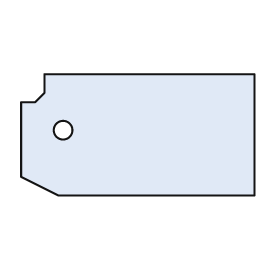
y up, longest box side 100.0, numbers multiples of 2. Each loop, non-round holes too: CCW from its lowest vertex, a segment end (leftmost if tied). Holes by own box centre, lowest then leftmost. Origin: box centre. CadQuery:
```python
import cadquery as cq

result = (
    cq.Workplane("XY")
    .moveTo(-34.0, -26.0)
    .lineTo(50.0, -26.0)
    .lineTo(50.0, 26.0)
    .lineTo(-40.0, 26.0)
    .lineTo(-40.0, 18.0)
    .lineTo(-44.0, 14.0)
    .lineTo(-50.0, 14.0)
    .lineTo(-50.0, -18.0)
    .close()
    .moveTo(-32.0, 2.0)
    .circle(4.0)
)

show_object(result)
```